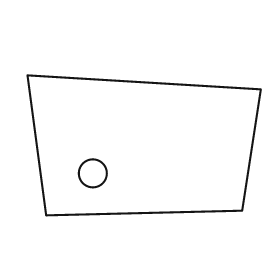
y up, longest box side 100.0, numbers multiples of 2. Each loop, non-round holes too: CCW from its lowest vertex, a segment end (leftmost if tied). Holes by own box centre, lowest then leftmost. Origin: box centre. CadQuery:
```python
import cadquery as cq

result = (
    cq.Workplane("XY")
    .moveTo(-42.0, -30.0)
    .lineTo(42.0, -28.0)
    .lineTo(50.0, 24.0)
    .lineTo(-50.0, 30.0)
    .close()
    .moveTo(-22.0, -12.0)
    .circle(6.0)
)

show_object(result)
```